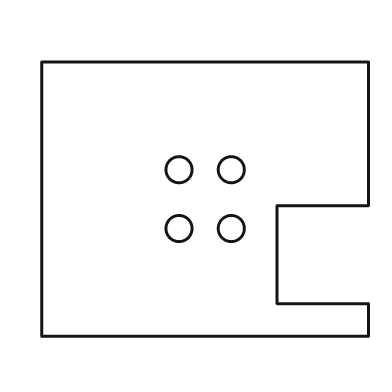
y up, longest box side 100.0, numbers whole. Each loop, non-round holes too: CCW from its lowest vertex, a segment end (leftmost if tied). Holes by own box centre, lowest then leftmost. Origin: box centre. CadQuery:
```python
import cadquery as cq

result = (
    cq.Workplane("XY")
    .moveTo(-50.0, -42.0)
    .lineTo(50.0, -42.0)
    .lineTo(50.0, -32.0)
    .lineTo(22.0, -32.0)
    .lineTo(22.0, -2.0)
    .lineTo(50.0, -2.0)
    .lineTo(50.0, 42.0)
    .lineTo(-50.0, 42.0)
    .close()
    .moveTo(-8.0, -9.0)
    .circle(4.0)
    .moveTo(8.0, -9.0)
    .circle(4.0)
    .moveTo(-8.0, 9.0)
    .circle(4.0)
    .moveTo(8.0, 9.0)
    .circle(4.0)
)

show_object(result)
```